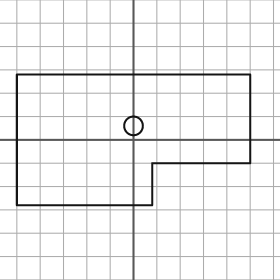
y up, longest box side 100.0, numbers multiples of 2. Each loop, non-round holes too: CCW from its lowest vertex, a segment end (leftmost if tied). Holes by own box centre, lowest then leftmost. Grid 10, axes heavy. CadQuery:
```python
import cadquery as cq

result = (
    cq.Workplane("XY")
    .moveTo(-50.0, -28.0)
    .lineTo(8.0, -28.0)
    .lineTo(8.0, -10.0)
    .lineTo(50.0, -10.0)
    .lineTo(50.0, 28.0)
    .lineTo(-50.0, 28.0)
    .close()
    .moveTo(0.0, 6.0)
    .circle(4.0)
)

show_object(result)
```